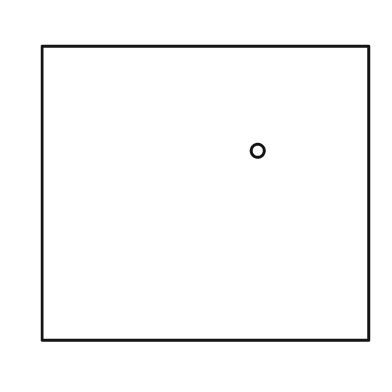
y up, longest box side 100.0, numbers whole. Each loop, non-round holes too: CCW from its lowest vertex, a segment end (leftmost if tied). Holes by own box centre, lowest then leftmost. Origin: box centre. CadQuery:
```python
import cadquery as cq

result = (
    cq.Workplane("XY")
    .moveTo(-50.0, -45.0)
    .lineTo(50.0, -45.0)
    .lineTo(50.0, 45.0)
    .lineTo(-50.0, 45.0)
    .close()
    .moveTo(16.0, 13.0)
    .circle(2.0)
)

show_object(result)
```